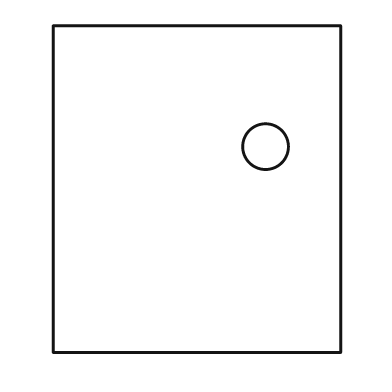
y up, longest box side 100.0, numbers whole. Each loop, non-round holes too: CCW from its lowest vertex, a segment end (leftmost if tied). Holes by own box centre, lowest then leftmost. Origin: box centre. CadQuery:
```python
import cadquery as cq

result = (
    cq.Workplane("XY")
    .moveTo(-44.0, -50.0)
    .lineTo(44.0, -50.0)
    .lineTo(44.0, 50.0)
    .lineTo(-44.0, 50.0)
    .close()
    .moveTo(21.0, 13.0)
    .circle(7.0)
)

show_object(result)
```